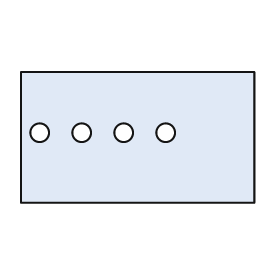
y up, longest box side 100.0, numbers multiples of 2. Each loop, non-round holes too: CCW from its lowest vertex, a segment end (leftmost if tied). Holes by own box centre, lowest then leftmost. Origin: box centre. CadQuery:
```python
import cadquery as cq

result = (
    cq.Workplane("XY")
    .moveTo(-50.0, -28.0)
    .lineTo(50.0, -28.0)
    .lineTo(50.0, 28.0)
    .lineTo(-50.0, 28.0)
    .close()
    .moveTo(-42.0, 2.0)
    .circle(4.0)
    .moveTo(-24.0, 2.0)
    .circle(4.0)
    .moveTo(-6.0, 2.0)
    .circle(4.0)
    .moveTo(12.0, 2.0)
    .circle(4.0)
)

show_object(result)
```